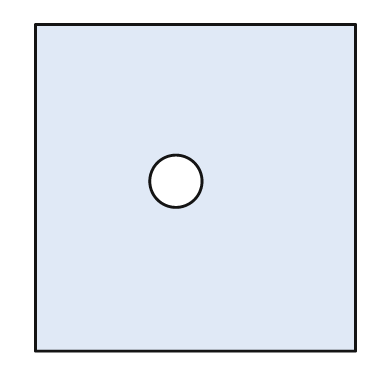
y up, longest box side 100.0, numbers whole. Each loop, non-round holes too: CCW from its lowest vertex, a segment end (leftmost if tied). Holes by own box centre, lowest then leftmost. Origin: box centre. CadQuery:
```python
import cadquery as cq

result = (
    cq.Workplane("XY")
    .moveTo(-49.0, -50.0)
    .lineTo(49.0, -50.0)
    .lineTo(49.0, 50.0)
    .lineTo(-49.0, 50.0)
    .close()
    .moveTo(-6.0, 2.0)
    .circle(8.0)
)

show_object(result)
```